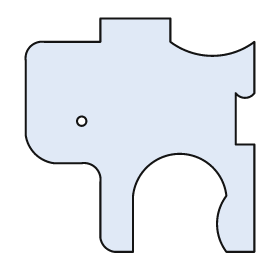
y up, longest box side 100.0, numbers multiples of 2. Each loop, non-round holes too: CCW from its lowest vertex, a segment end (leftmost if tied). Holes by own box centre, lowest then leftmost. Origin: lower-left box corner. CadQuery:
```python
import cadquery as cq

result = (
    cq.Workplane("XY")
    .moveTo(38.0, 0.0)
    .lineTo(46.0, 0.0)
    .lineTo(46.0, 24.0)
    .threePointArc((66.0, 42.0), (86.0, 24.0))
    .threePointArc((82.0, 12.0), (86.0, 0.0))
    .lineTo(98.0, 0.0)
    .lineTo(98.0, 46.0)
    .lineTo(90.0, 46.0)
    .lineTo(90.0, 68.0)
    .threePointArc((94.0, 66.0), (98.0, 68.0))
    .lineTo(98.0, 90.0)
    .threePointArc((80.0, 84.0), (62.0, 90.0))
    .lineTo(62.0, 100.0)
    .lineTo(32.0, 100.0)
    .lineTo(32.0, 90.0)
    .lineTo(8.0, 90.0)
    .threePointArc((2.0, 88.0), (0.0, 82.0))
    .lineTo(0.0, 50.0)
    .threePointArc((4.0, 42.0), (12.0, 38.0))
    .lineTo(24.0, 38.0)
    .threePointArc((30.0, 36.0), (32.0, 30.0))
    .lineTo(32.0, 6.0)
    .threePointArc((34.0, 2.0), (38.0, 0.0))
    .close()
    .moveTo(24.0, 56.0)
    .circle(2.0)
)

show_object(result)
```